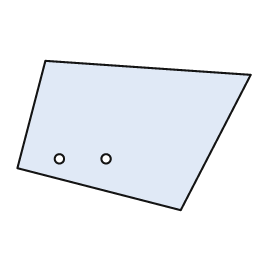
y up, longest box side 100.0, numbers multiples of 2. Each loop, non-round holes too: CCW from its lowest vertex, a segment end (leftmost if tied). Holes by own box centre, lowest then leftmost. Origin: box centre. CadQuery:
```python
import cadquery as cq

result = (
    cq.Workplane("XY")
    .moveTo(20.0, -32.0)
    .lineTo(50.0, 26.0)
    .lineTo(-38.0, 32.0)
    .lineTo(-50.0, -14.0)
    .close()
    .moveTo(-32.0, -10.0)
    .circle(2.0)
    .moveTo(-12.0, -10.0)
    .circle(2.0)
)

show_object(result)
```